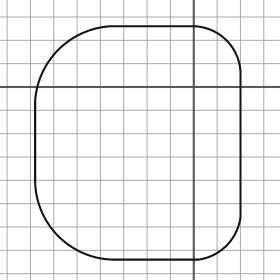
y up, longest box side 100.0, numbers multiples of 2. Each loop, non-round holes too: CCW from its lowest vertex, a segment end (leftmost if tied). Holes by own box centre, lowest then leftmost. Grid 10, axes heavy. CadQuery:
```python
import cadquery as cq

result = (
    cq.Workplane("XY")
    .moveTo(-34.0, -74.0)
    .lineTo(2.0, -74.0)
    .threePointArc((14.0, -68.0), (20.0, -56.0))
    .lineTo(20.0, 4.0)
    .threePointArc((14.0, 20.0), (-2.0, 26.0))
    .lineTo(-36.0, 26.0)
    .threePointArc((-58.0, 16.0), (-68.0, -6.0))
    .lineTo(-68.0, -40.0)
    .threePointArc((-58.0, -64.0), (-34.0, -74.0))
    .close()
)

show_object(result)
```